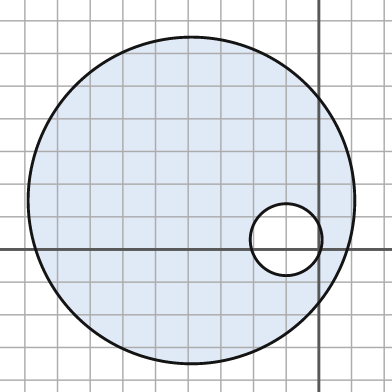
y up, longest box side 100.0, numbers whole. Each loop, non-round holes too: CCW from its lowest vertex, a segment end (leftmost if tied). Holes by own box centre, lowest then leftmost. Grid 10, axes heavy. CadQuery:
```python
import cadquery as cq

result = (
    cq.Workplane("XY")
    .moveTo(-39.0, 15.0)
    .circle(50.0)
    .moveTo(-10.0, 3.0)
    .circle(11.0)
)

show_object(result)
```